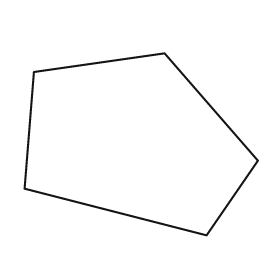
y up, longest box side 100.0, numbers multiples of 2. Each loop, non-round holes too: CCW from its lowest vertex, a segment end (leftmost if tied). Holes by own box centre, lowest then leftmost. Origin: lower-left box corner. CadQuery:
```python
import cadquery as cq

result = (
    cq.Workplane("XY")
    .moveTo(78.0, 0.0)
    .lineTo(100.0, 32.0)
    .lineTo(60.0, 78.0)
    .lineTo(4.0, 70.0)
    .lineTo(0.0, 20.0)
    .close()
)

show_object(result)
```